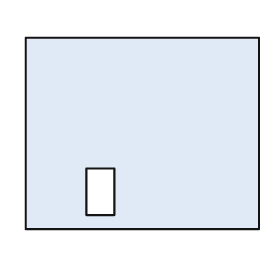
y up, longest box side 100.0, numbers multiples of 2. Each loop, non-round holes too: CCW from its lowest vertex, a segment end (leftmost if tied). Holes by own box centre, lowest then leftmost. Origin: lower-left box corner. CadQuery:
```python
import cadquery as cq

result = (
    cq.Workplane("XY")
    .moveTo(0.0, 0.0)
    .lineTo(100.0, 0.0)
    .lineTo(100.0, 82.0)
    .lineTo(0.0, 82.0)
    .close()
    .moveTo(26.0, 6.0)
    .lineTo(38.0, 6.0)
    .lineTo(38.0, 26.0)
    .lineTo(26.0, 26.0)
    .close()
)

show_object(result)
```